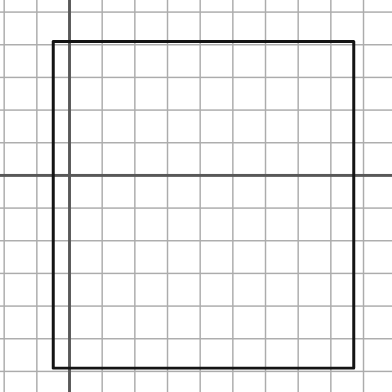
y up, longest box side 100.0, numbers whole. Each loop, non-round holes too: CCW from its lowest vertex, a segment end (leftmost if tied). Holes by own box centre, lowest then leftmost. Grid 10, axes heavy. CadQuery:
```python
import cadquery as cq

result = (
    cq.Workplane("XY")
    .moveTo(-5.0, -59.0)
    .lineTo(87.0, -59.0)
    .lineTo(87.0, 41.0)
    .lineTo(-5.0, 41.0)
    .close()
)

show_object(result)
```